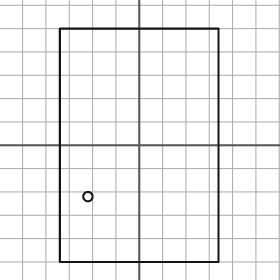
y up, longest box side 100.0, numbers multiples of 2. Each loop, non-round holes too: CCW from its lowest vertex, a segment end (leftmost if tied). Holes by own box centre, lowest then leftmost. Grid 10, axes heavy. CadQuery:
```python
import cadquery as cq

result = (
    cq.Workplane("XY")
    .moveTo(-34.0, -50.0)
    .lineTo(34.0, -50.0)
    .lineTo(34.0, 50.0)
    .lineTo(-34.0, 50.0)
    .close()
    .moveTo(-22.0, -22.0)
    .circle(2.0)
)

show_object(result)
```